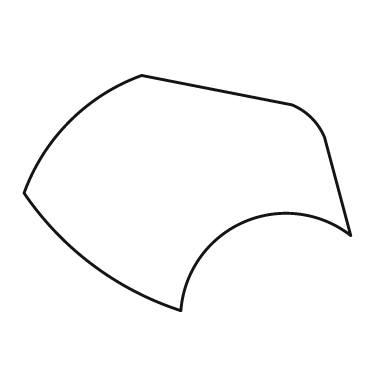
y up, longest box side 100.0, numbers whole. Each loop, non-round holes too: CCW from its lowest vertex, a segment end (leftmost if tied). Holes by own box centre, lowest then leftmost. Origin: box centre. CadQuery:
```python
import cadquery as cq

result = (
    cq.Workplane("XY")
    .moveTo(-2.0, -36.0)
    .threePointArc((17.0, -9.0), (50.0, -13.0))
    .lineTo(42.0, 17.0)
    .threePointArc((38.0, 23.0), (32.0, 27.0))
    .lineTo(-14.0, 36.0)
    .threePointArc((-36.0, 22.0), (-50.0, 0.0))
    .threePointArc((-29.0, -22.0), (-2.0, -36.0))
    .close()
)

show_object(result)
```